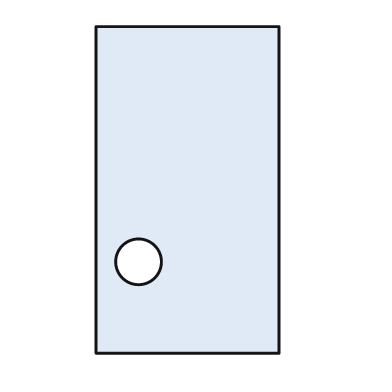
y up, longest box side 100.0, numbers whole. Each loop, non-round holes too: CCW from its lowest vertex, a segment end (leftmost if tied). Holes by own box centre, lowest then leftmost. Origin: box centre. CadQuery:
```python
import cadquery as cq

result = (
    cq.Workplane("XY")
    .moveTo(-28.0, -50.0)
    .lineTo(28.0, -50.0)
    .lineTo(28.0, 50.0)
    .lineTo(-28.0, 50.0)
    .close()
    .moveTo(-15.0, -22.0)
    .circle(7.0)
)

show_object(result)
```